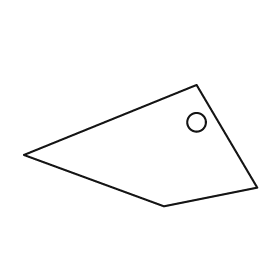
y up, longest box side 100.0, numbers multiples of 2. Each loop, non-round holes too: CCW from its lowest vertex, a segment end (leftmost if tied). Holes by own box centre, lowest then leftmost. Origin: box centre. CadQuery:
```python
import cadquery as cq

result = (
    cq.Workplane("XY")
    .moveTo(10.0, -26.0)
    .lineTo(50.0, -18.0)
    .lineTo(24.0, 26.0)
    .lineTo(-50.0, -4.0)
    .close()
    .moveTo(24.0, 10.0)
    .circle(4.0)
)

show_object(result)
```